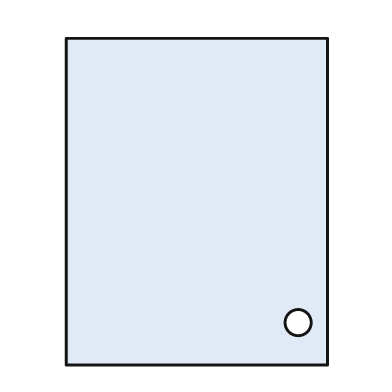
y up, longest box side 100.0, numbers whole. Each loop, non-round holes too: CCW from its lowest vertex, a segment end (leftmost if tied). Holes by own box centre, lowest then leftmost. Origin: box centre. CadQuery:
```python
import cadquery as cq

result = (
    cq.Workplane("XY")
    .moveTo(-40.0, -50.0)
    .lineTo(40.0, -50.0)
    .lineTo(40.0, 50.0)
    .lineTo(-40.0, 50.0)
    .close()
    .moveTo(31.0, -37.0)
    .circle(4.0)
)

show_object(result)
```